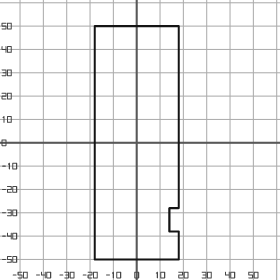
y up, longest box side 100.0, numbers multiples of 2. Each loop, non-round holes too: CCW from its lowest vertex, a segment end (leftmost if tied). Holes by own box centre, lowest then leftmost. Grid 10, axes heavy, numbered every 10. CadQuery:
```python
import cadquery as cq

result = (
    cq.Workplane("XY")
    .moveTo(-18.0, -50.0)
    .lineTo(18.0, -50.0)
    .lineTo(18.0, -38.0)
    .lineTo(14.0, -38.0)
    .lineTo(14.0, -28.0)
    .lineTo(18.0, -28.0)
    .lineTo(18.0, 50.0)
    .lineTo(-18.0, 50.0)
    .close()
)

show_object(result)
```